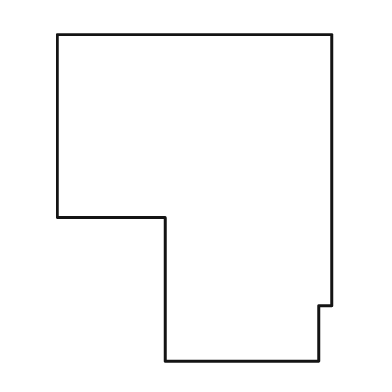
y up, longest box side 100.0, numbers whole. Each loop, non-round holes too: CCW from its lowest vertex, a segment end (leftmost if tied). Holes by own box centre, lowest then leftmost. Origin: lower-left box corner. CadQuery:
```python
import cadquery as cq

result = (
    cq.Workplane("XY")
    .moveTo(33.0, 0.0)
    .lineTo(80.0, 0.0)
    .lineTo(80.0, 17.0)
    .lineTo(84.0, 17.0)
    .lineTo(84.0, 100.0)
    .lineTo(0.0, 100.0)
    .lineTo(0.0, 44.0)
    .lineTo(33.0, 44.0)
    .close()
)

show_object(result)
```